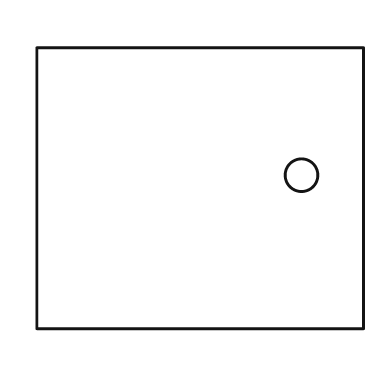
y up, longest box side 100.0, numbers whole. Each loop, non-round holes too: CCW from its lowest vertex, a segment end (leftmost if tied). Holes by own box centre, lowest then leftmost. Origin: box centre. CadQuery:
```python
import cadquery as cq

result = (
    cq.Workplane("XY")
    .moveTo(-50.0, -43.0)
    .lineTo(50.0, -43.0)
    .lineTo(50.0, 43.0)
    .lineTo(-50.0, 43.0)
    .close()
    .moveTo(31.0, 4.0)
    .circle(5.0)
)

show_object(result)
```